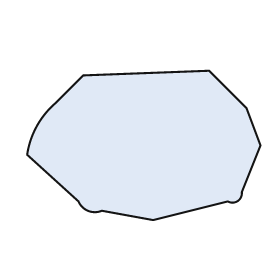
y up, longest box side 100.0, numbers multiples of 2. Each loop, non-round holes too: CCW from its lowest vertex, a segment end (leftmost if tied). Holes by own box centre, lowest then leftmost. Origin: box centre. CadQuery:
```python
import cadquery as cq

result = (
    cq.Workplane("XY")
    .moveTo(4.0, -32.0)
    .lineTo(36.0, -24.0)
    .threePointArc((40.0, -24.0), (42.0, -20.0))
    .lineTo(50.0, 0.0)
    .lineTo(44.0, 16.0)
    .lineTo(28.0, 32.0)
    .lineTo(-26.0, 30.0)
    .lineTo(-38.0, 18.0)
    .threePointArc((-46.0, 8.0), (-50.0, -4.0))
    .lineTo(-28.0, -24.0)
    .threePointArc((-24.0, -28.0), (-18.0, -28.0))
    .close()
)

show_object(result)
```